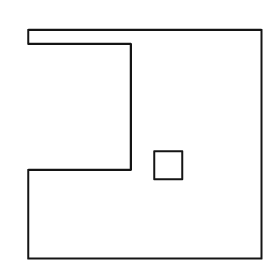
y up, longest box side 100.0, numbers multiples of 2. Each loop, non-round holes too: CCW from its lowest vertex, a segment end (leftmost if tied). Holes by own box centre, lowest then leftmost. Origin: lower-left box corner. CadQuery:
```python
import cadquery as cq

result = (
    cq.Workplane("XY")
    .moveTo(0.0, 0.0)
    .lineTo(100.0, 0.0)
    .lineTo(100.0, 98.0)
    .lineTo(0.0, 98.0)
    .lineTo(0.0, 92.0)
    .lineTo(44.0, 92.0)
    .lineTo(44.0, 38.0)
    .lineTo(0.0, 38.0)
    .close()
    .moveTo(54.0, 34.0)
    .lineTo(66.0, 34.0)
    .lineTo(66.0, 46.0)
    .lineTo(54.0, 46.0)
    .close()
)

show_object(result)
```